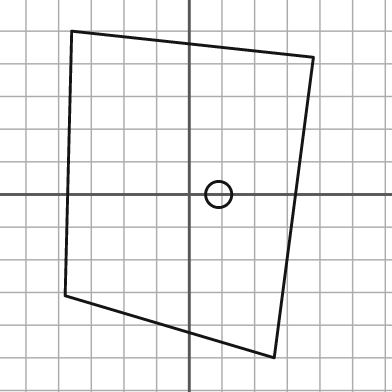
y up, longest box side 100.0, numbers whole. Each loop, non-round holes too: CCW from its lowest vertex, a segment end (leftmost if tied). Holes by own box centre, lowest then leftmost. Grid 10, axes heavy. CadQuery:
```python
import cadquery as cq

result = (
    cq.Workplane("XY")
    .moveTo(26.0, -50.0)
    .lineTo(38.0, 42.0)
    .lineTo(-36.0, 50.0)
    .lineTo(-38.0, -31.0)
    .close()
    .moveTo(9.0, 0.0)
    .circle(4.0)
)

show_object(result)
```